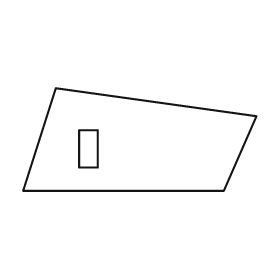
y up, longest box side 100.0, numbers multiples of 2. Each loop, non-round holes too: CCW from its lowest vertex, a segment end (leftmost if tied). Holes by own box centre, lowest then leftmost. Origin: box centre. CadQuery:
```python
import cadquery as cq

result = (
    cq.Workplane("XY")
    .moveTo(-50.0, -22.0)
    .lineTo(36.0, -22.0)
    .lineTo(50.0, 10.0)
    .lineTo(-36.0, 22.0)
    .close()
    .moveTo(-26.0, -12.0)
    .lineTo(-18.0, -12.0)
    .lineTo(-18.0, 4.0)
    .lineTo(-26.0, 4.0)
    .close()
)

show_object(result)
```